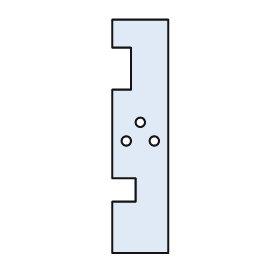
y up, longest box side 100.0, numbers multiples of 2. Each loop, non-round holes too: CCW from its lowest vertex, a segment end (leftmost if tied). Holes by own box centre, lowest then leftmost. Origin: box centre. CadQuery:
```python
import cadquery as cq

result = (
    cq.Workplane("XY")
    .moveTo(-12.0, -50.0)
    .lineTo(12.0, -50.0)
    .lineTo(12.0, 50.0)
    .lineTo(-12.0, 50.0)
    .lineTo(-12.0, 38.0)
    .lineTo(-4.0, 38.0)
    .lineTo(-4.0, 20.0)
    .lineTo(-12.0, 20.0)
    .lineTo(-12.0, -18.0)
    .lineTo(-2.0, -18.0)
    .lineTo(-2.0, -28.0)
    .lineTo(-12.0, -28.0)
    .close()
    .moveTo(-6.0, -2.0)
    .circle(2.0)
    .moveTo(6.0, -2.0)
    .circle(2.0)
    .moveTo(0.0, 6.0)
    .circle(2.0)
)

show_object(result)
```